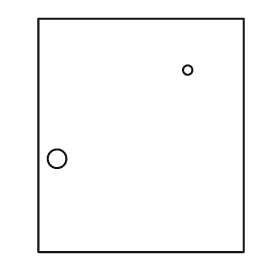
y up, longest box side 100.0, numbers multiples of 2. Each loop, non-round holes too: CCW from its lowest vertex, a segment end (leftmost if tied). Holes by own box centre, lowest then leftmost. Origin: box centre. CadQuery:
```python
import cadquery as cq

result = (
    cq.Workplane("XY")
    .moveTo(-44.0, -50.0)
    .lineTo(44.0, -50.0)
    .lineTo(44.0, 50.0)
    .lineTo(-44.0, 50.0)
    .close()
    .moveTo(-36.0, -10.0)
    .circle(4.0)
    .moveTo(20.0, 28.0)
    .circle(2.0)
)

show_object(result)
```